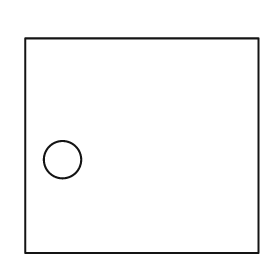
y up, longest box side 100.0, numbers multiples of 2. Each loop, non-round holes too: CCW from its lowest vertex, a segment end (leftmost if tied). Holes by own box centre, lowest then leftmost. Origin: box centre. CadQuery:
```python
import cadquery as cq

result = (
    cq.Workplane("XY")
    .moveTo(-50.0, -46.0)
    .lineTo(50.0, -46.0)
    .lineTo(50.0, 46.0)
    .lineTo(-50.0, 46.0)
    .close()
    .moveTo(-34.0, -6.0)
    .circle(8.0)
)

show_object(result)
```